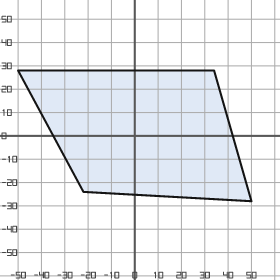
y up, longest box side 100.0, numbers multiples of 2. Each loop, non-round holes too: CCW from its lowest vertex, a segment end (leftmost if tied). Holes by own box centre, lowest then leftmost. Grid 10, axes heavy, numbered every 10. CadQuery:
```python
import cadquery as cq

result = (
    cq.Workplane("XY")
    .moveTo(50.0, -28.0)
    .lineTo(34.0, 28.0)
    .lineTo(-50.0, 28.0)
    .lineTo(-22.0, -24.0)
    .close()
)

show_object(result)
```